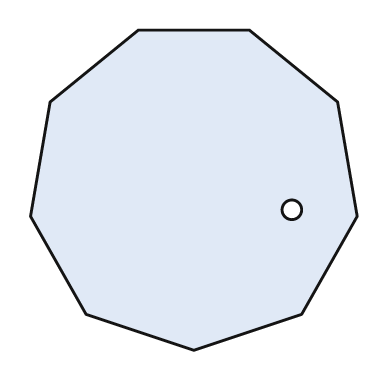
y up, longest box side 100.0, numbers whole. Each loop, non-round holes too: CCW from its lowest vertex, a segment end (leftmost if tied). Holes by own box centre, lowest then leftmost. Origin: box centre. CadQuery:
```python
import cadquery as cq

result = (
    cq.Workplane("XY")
    .moveTo(0.0, -49.0)
    .lineTo(33.0, -38.0)
    .lineTo(50.0, -8.0)
    .lineTo(44.0, 27.0)
    .lineTo(17.0, 49.0)
    .lineTo(-17.0, 49.0)
    .lineTo(-44.0, 27.0)
    .lineTo(-50.0, -8.0)
    .lineTo(-33.0, -38.0)
    .close()
    .moveTo(30.0, -6.0)
    .circle(3.0)
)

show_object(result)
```